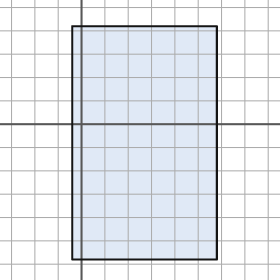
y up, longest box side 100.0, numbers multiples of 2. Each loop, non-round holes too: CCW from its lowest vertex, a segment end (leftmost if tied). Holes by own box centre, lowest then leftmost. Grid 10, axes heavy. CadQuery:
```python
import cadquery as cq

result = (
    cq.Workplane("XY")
    .moveTo(-4.0, -58.0)
    .lineTo(58.0, -58.0)
    .lineTo(58.0, 42.0)
    .lineTo(-4.0, 42.0)
    .close()
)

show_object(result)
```